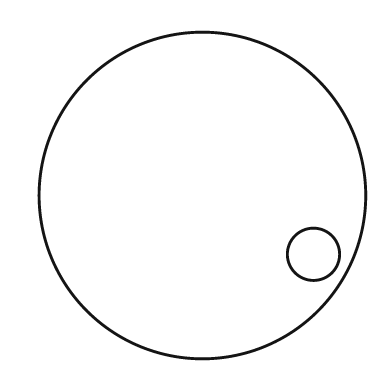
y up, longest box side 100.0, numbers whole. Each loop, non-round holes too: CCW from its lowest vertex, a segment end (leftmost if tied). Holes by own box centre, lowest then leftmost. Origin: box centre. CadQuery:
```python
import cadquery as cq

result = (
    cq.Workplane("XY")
    .moveTo(0.0, 0.0)
    .circle(50.0)
    .moveTo(34.0, -18.0)
    .circle(8.0)
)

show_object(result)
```